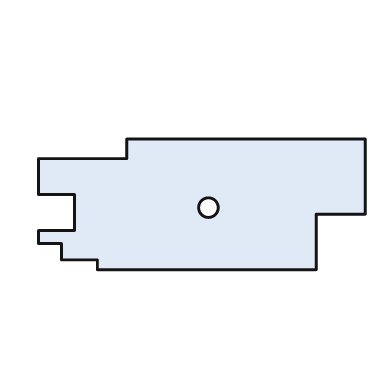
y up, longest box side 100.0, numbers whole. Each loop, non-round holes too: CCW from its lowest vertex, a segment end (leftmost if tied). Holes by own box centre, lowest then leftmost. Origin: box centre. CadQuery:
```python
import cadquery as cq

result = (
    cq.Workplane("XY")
    .moveTo(-32.0, -20.0)
    .lineTo(35.0, -20.0)
    .lineTo(35.0, -3.0)
    .lineTo(50.0, -3.0)
    .lineTo(50.0, 20.0)
    .lineTo(-23.0, 20.0)
    .lineTo(-23.0, 14.0)
    .lineTo(-50.0, 14.0)
    .lineTo(-50.0, 3.0)
    .lineTo(-39.0, 3.0)
    .lineTo(-39.0, -8.0)
    .lineTo(-50.0, -8.0)
    .lineTo(-50.0, -12.0)
    .lineTo(-43.0, -12.0)
    .lineTo(-43.0, -17.0)
    .lineTo(-32.0, -17.0)
    .close()
    .moveTo(2.0, -1.0)
    .circle(3.0)
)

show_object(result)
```